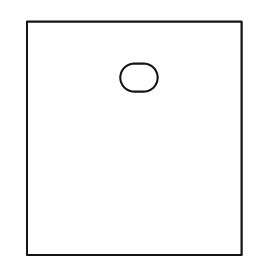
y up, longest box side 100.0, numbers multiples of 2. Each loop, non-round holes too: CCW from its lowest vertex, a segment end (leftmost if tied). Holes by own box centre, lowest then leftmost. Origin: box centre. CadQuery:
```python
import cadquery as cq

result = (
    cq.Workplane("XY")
    .moveTo(-46.0, -50.0)
    .lineTo(46.0, -50.0)
    .lineTo(46.0, 50.0)
    .lineTo(-46.0, 50.0)
    .close()
    .moveTo(0.0, 20.0)
    .lineTo(4.0, 20.0)
    .threePointArc((10.0, 26.0), (4.0, 32.0))
    .lineTo(0.0, 32.0)
    .threePointArc((-6.0, 26.0), (0.0, 20.0))
    .close()
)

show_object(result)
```